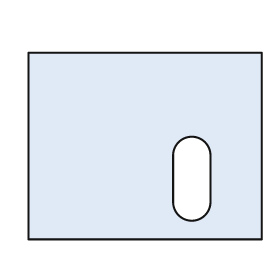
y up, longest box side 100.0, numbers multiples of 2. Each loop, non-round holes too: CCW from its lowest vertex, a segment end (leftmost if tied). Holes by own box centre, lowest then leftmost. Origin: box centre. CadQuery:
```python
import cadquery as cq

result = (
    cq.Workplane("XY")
    .moveTo(-50.0, -40.0)
    .lineTo(50.0, -40.0)
    .lineTo(50.0, 40.0)
    .lineTo(-50.0, 40.0)
    .close()
    .moveTo(12.0, -24.0)
    .threePointArc((20.0, -32.0), (28.0, -24.0))
    .lineTo(28.0, -4.0)
    .threePointArc((20.0, 4.0), (12.0, -4.0))
    .close()
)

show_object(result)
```